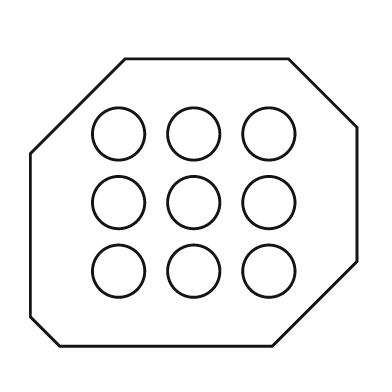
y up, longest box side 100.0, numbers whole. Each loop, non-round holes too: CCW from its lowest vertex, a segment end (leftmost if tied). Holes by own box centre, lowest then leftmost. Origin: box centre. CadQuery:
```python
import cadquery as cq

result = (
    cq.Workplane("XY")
    .moveTo(-41.0, -44.0)
    .lineTo(24.0, -44.0)
    .lineTo(50.0, -18.0)
    .lineTo(50.0, 23.0)
    .lineTo(29.0, 44.0)
    .lineTo(-21.0, 44.0)
    .lineTo(-50.0, 15.0)
    .lineTo(-50.0, -35.0)
    .close()
    .moveTo(-23.0, -21.0)
    .circle(8.0)
    .moveTo(0.0, -21.0)
    .circle(8.0)
    .moveTo(23.0, -21.0)
    .circle(8.0)
    .moveTo(-23.0, 0.0)
    .circle(8.0)
    .moveTo(0.0, 0.0)
    .circle(8.0)
    .moveTo(23.0, 0.0)
    .circle(8.0)
    .moveTo(-23.0, 21.0)
    .circle(8.0)
    .moveTo(0.0, 21.0)
    .circle(8.0)
    .moveTo(23.0, 21.0)
    .circle(8.0)
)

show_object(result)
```